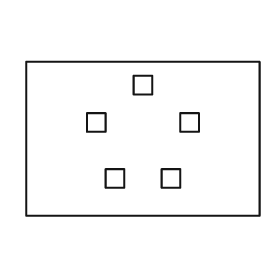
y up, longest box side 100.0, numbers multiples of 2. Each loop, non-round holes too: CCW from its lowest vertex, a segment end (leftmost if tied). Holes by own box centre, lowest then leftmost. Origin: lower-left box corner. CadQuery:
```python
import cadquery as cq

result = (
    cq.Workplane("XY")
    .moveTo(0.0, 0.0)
    .lineTo(100.0, 0.0)
    .lineTo(100.0, 66.0)
    .lineTo(0.0, 66.0)
    .close()
    .moveTo(34.0, 12.0)
    .lineTo(42.0, 12.0)
    .lineTo(42.0, 20.0)
    .lineTo(34.0, 20.0)
    .close()
    .moveTo(58.0, 12.0)
    .lineTo(66.0, 12.0)
    .lineTo(66.0, 20.0)
    .lineTo(58.0, 20.0)
    .close()
    .moveTo(26.0, 36.0)
    .lineTo(34.0, 36.0)
    .lineTo(34.0, 44.0)
    .lineTo(26.0, 44.0)
    .close()
    .moveTo(66.0, 36.0)
    .lineTo(74.0, 36.0)
    .lineTo(74.0, 44.0)
    .lineTo(66.0, 44.0)
    .close()
    .moveTo(46.0, 52.0)
    .lineTo(54.0, 52.0)
    .lineTo(54.0, 60.0)
    .lineTo(46.0, 60.0)
    .close()
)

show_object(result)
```